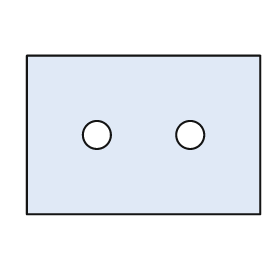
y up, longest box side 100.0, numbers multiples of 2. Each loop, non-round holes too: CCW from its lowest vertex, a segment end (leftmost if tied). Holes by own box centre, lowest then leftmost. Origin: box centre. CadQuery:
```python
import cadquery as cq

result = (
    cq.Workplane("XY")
    .moveTo(-50.0, -34.0)
    .lineTo(50.0, -34.0)
    .lineTo(50.0, 34.0)
    .lineTo(-50.0, 34.0)
    .close()
    .moveTo(-20.0, 0.0)
    .circle(6.0)
    .moveTo(20.0, 0.0)
    .circle(6.0)
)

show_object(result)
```